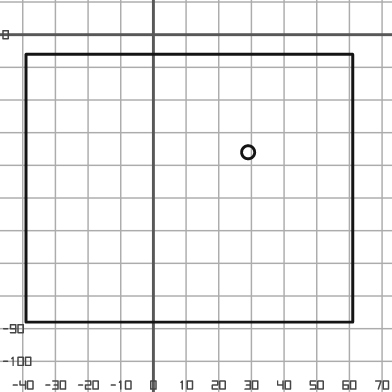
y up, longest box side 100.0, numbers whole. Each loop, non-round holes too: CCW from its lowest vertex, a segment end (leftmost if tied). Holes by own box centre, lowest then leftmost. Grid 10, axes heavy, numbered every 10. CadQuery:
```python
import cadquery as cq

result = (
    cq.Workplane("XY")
    .moveTo(-39.0, -88.0)
    .lineTo(61.0, -88.0)
    .lineTo(61.0, -6.0)
    .lineTo(-39.0, -6.0)
    .close()
    .moveTo(29.0, -36.0)
    .circle(2.0)
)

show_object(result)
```